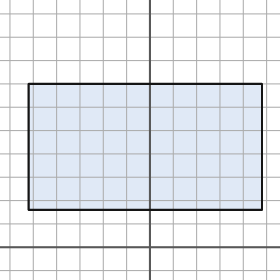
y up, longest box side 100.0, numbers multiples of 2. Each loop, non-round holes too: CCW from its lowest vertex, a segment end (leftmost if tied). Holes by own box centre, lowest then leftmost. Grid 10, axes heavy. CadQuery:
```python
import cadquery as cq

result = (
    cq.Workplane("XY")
    .moveTo(-52.0, 16.0)
    .lineTo(48.0, 16.0)
    .lineTo(48.0, 70.0)
    .lineTo(-52.0, 70.0)
    .close()
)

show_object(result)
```